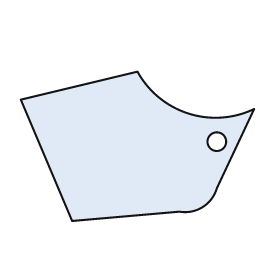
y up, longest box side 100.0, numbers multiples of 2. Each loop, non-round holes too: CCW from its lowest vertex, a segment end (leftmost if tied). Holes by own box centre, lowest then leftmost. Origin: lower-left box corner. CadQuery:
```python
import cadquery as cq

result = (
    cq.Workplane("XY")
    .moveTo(22.0, 0.0)
    .lineTo(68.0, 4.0)
    .threePointArc((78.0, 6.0), (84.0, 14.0))
    .lineTo(100.0, 48.0)
    .threePointArc((72.0, 46.0), (50.0, 64.0))
    .lineTo(0.0, 52.0)
    .close()
    .moveTo(84.0, 34.0)
    .circle(4.0)
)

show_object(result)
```